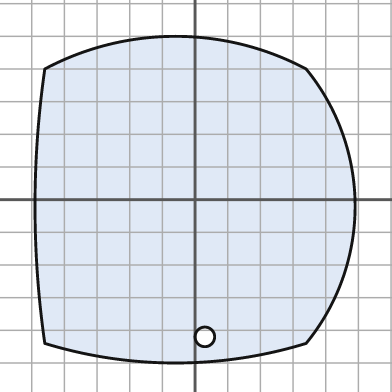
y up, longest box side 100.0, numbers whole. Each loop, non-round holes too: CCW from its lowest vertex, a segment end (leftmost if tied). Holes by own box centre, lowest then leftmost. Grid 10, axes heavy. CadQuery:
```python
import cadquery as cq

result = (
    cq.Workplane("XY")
    .moveTo(-46.0, -44.0)
    .threePointArc((-6.0, -50.0), (34.0, -44.0))
    .threePointArc((49.0, -2.0), (34.0, 40.0))
    .threePointArc((-6.0, 50.0), (-46.0, 40.0))
    .threePointArc((-49.0, -2.0), (-46.0, -44.0))
    .close()
    .moveTo(3.0, -42.0)
    .circle(3.0)
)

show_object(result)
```